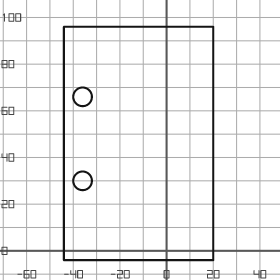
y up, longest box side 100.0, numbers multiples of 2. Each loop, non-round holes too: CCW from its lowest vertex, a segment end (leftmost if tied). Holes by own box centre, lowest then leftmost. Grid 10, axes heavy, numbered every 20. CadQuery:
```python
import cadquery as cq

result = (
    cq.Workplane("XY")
    .moveTo(-44.0, -4.0)
    .lineTo(20.0, -4.0)
    .lineTo(20.0, 96.0)
    .lineTo(-44.0, 96.0)
    .close()
    .moveTo(-36.0, 30.0)
    .circle(4.0)
    .moveTo(-36.0, 66.0)
    .circle(4.0)
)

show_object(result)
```